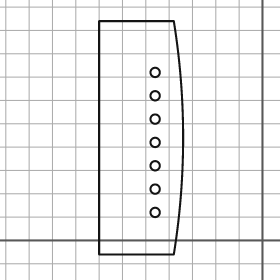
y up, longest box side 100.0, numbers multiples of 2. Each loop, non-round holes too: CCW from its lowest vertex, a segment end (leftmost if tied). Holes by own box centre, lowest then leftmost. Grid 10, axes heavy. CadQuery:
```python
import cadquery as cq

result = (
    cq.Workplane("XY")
    .moveTo(-70.0, -6.0)
    .lineTo(-38.0, -6.0)
    .threePointArc((-34.0, 44.0), (-38.0, 94.0))
    .lineTo(-70.0, 94.0)
    .close()
    .moveTo(-46.0, 12.0)
    .circle(2.0)
    .moveTo(-46.0, 22.0)
    .circle(2.0)
    .moveTo(-46.0, 32.0)
    .circle(2.0)
    .moveTo(-46.0, 42.0)
    .circle(2.0)
    .moveTo(-46.0, 52.0)
    .circle(2.0)
    .moveTo(-46.0, 62.0)
    .circle(2.0)
    .moveTo(-46.0, 72.0)
    .circle(2.0)
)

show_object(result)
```